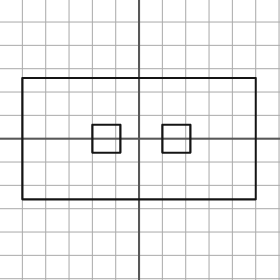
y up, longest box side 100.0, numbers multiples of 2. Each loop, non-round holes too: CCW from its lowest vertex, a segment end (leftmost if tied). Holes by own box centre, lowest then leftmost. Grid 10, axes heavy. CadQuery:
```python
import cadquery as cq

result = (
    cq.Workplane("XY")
    .moveTo(-50.0, -26.0)
    .lineTo(50.0, -26.0)
    .lineTo(50.0, 26.0)
    .lineTo(-50.0, 26.0)
    .close()
    .moveTo(-20.0, -6.0)
    .lineTo(-8.0, -6.0)
    .lineTo(-8.0, 6.0)
    .lineTo(-20.0, 6.0)
    .close()
    .moveTo(10.0, -6.0)
    .lineTo(22.0, -6.0)
    .lineTo(22.0, 6.0)
    .lineTo(10.0, 6.0)
    .close()
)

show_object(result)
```